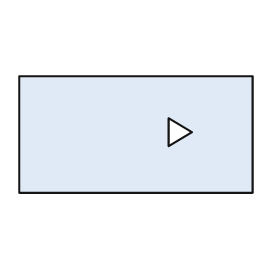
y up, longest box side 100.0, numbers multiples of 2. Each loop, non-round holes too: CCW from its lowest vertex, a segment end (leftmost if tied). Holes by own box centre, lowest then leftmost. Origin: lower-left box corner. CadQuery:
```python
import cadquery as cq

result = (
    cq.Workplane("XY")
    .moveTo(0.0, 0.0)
    .lineTo(100.0, 0.0)
    .lineTo(100.0, 50.0)
    .lineTo(0.0, 50.0)
    .close()
    .moveTo(64.0, 20.0)
    .lineTo(74.0, 26.0)
    .lineTo(64.0, 32.0)
    .close()
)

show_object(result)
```